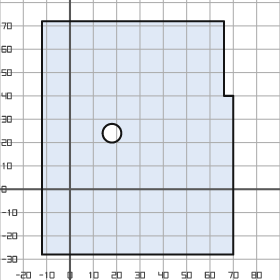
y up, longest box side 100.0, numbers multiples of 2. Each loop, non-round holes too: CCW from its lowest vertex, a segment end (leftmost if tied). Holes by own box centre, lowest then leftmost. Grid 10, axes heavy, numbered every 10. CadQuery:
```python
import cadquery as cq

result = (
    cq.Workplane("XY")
    .moveTo(-12.0, -28.0)
    .lineTo(70.0, -28.0)
    .lineTo(70.0, 40.0)
    .lineTo(66.0, 40.0)
    .lineTo(66.0, 72.0)
    .lineTo(-12.0, 72.0)
    .close()
    .moveTo(18.0, 24.0)
    .circle(4.0)
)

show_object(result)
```